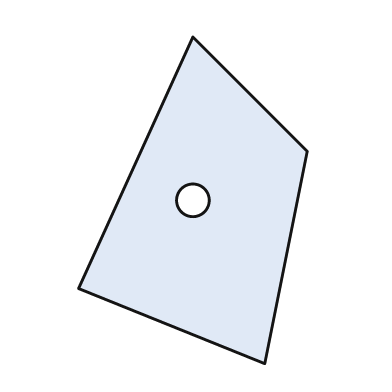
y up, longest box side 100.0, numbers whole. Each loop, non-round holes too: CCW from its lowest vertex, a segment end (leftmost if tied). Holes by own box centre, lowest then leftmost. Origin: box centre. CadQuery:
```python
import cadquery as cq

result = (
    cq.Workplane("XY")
    .moveTo(22.0, -50.0)
    .lineTo(35.0, 15.0)
    .lineTo(0.0, 50.0)
    .lineTo(-35.0, -27.0)
    .close()
    .moveTo(0.0, 0.0)
    .circle(5.0)
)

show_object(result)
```